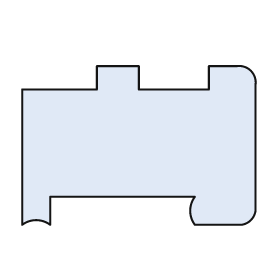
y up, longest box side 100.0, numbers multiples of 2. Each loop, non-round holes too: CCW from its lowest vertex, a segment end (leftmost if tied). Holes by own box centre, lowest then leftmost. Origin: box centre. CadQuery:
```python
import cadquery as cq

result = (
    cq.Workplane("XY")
    .moveTo(-50.0, -34.0)
    .threePointArc((-44.0, -32.0), (-38.0, -34.0))
    .lineTo(-38.0, -22.0)
    .lineTo(24.0, -22.0)
    .threePointArc((22.0, -28.0), (24.0, -34.0))
    .lineTo(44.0, -34.0)
    .threePointArc((48.0, -32.0), (50.0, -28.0))
    .lineTo(50.0, 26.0)
    .threePointArc((48.0, 32.0), (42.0, 34.0))
    .lineTo(30.0, 34.0)
    .lineTo(30.0, 24.0)
    .lineTo(0.0, 24.0)
    .lineTo(0.0, 34.0)
    .lineTo(-18.0, 34.0)
    .lineTo(-18.0, 24.0)
    .lineTo(-50.0, 24.0)
    .close()
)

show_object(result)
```